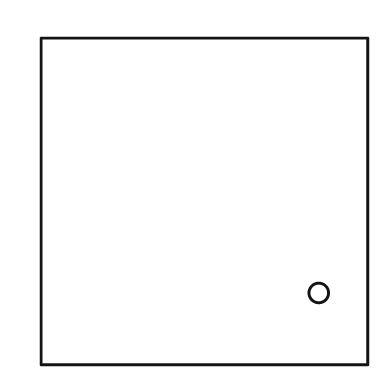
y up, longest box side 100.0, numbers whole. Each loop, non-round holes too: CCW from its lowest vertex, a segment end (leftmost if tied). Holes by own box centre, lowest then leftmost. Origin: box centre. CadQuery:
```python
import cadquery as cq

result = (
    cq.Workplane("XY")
    .moveTo(-50.0, -50.0)
    .lineTo(50.0, -50.0)
    .lineTo(50.0, 50.0)
    .lineTo(-50.0, 50.0)
    .close()
    .moveTo(35.0, -28.0)
    .circle(3.0)
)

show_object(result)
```